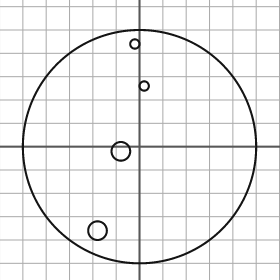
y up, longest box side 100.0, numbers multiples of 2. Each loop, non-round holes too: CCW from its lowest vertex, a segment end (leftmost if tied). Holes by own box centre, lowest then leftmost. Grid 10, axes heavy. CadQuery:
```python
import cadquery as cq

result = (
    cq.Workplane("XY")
    .moveTo(0.0, 0.0)
    .circle(50.0)
    .moveTo(-18.0, -36.0)
    .circle(4.0)
    .moveTo(-8.0, -2.0)
    .circle(4.0)
    .moveTo(2.0, 26.0)
    .circle(2.0)
    .moveTo(-2.0, 44.0)
    .circle(2.0)
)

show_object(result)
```